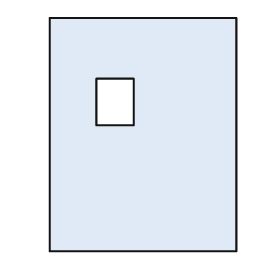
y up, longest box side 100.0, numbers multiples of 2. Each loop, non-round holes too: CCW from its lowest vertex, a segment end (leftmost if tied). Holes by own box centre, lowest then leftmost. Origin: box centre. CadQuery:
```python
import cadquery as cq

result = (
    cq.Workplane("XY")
    .moveTo(-40.0, -50.0)
    .lineTo(40.0, -50.0)
    .lineTo(40.0, 50.0)
    .lineTo(-40.0, 50.0)
    .close()
    .moveTo(-20.0, 4.0)
    .lineTo(-4.0, 4.0)
    .lineTo(-4.0, 24.0)
    .lineTo(-20.0, 24.0)
    .close()
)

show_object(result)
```